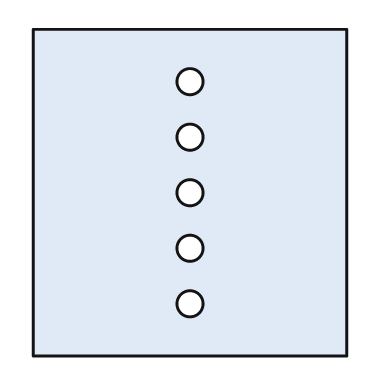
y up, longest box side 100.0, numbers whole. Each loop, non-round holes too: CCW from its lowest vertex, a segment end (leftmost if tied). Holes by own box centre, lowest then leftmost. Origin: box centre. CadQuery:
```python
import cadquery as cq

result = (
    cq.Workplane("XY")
    .moveTo(-48.0, -50.0)
    .lineTo(48.0, -50.0)
    .lineTo(48.0, 50.0)
    .lineTo(-48.0, 50.0)
    .close()
    .moveTo(0.0, -34.0)
    .circle(4.0)
    .moveTo(0.0, -17.0)
    .circle(4.0)
    .moveTo(0.0, 0.0)
    .circle(4.0)
    .moveTo(0.0, 17.0)
    .circle(4.0)
    .moveTo(0.0, 34.0)
    .circle(4.0)
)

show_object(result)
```